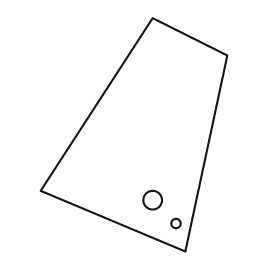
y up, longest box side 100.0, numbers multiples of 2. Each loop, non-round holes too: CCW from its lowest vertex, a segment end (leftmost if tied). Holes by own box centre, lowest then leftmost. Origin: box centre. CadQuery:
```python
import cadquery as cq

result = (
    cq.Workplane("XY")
    .moveTo(22.0, -50.0)
    .lineTo(40.0, 34.0)
    .lineTo(8.0, 50.0)
    .lineTo(-40.0, -24.0)
    .close()
    .moveTo(18.0, -38.0)
    .circle(2.0)
    .moveTo(8.0, -28.0)
    .circle(4.0)
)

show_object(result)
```